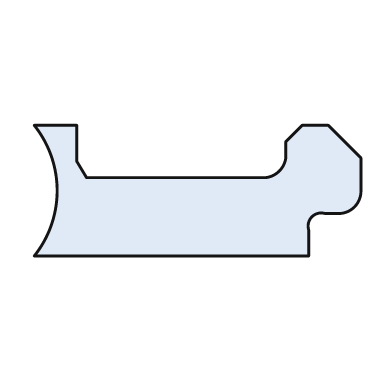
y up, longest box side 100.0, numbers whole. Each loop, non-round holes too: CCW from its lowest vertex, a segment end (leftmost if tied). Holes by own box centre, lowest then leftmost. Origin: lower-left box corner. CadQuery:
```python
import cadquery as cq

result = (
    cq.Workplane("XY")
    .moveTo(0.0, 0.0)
    .lineTo(84.0, 0.0)
    .lineTo(84.0, 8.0)
    .threePointArc((85.0, 12.0), (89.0, 13.0))
    .lineTo(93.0, 13.0)
    .threePointArc((98.0, 15.0), (100.0, 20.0))
    .lineTo(100.0, 30.0)
    .lineTo(90.0, 40.0)
    .lineTo(82.0, 40.0)
    .lineTo(77.0, 35.0)
    .lineTo(77.0, 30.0)
    .threePointArc((75.0, 26.0), (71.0, 24.0))
    .lineTo(16.0, 24.0)
    .lineTo(13.0, 29.0)
    .lineTo(13.0, 40.0)
    .lineTo(0.0, 40.0)
    .threePointArc((7.0, 20.0), (0.0, 0.0))
    .close()
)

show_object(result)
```